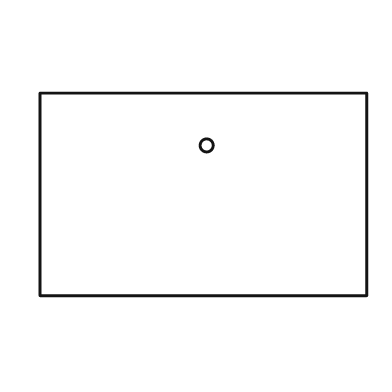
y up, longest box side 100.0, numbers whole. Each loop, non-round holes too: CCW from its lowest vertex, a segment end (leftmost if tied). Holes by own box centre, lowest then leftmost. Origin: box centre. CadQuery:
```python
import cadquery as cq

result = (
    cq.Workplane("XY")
    .moveTo(-50.0, -31.0)
    .lineTo(50.0, -31.0)
    .lineTo(50.0, 31.0)
    .lineTo(-50.0, 31.0)
    .close()
    .moveTo(1.0, 15.0)
    .circle(2.0)
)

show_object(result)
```